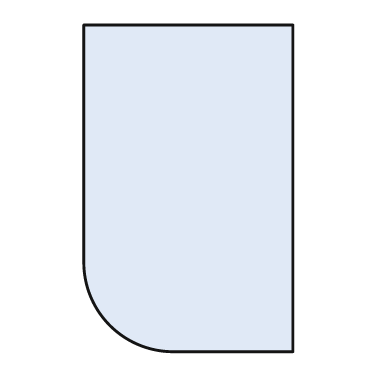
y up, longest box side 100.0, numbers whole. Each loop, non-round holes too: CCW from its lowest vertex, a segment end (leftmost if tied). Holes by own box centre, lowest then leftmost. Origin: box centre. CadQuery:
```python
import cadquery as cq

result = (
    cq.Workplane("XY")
    .moveTo(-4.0, -50.0)
    .lineTo(32.0, -50.0)
    .lineTo(32.0, 50.0)
    .lineTo(-32.0, 50.0)
    .lineTo(-32.0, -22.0)
    .threePointArc((-24.0, -42.0), (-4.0, -50.0))
    .close()
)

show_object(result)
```